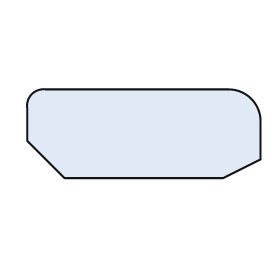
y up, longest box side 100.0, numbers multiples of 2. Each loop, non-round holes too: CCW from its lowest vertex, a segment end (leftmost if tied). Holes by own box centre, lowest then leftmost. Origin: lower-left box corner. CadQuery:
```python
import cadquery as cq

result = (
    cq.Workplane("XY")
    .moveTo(16.0, 0.0)
    .lineTo(84.0, 0.0)
    .lineTo(100.0, 8.0)
    .lineTo(100.0, 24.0)
    .threePointArc((96.0, 34.0), (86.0, 38.0))
    .lineTo(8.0, 38.0)
    .threePointArc((2.0, 36.0), (0.0, 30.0))
    .lineTo(0.0, 16.0)
    .close()
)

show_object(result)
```